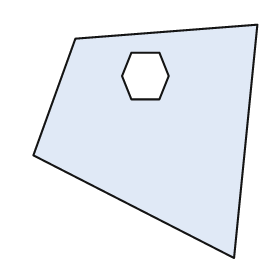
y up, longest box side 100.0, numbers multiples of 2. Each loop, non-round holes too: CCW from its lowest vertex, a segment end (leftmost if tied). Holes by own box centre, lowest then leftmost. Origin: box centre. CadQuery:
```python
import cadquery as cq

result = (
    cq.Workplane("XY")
    .moveTo(38.0, -50.0)
    .lineTo(48.0, 50.0)
    .lineTo(-30.0, 44.0)
    .lineTo(-48.0, -6.0)
    .close()
    .moveTo(-6.0, 18.0)
    .lineTo(6.0, 18.0)
    .lineTo(10.0, 28.0)
    .lineTo(6.0, 38.0)
    .lineTo(-6.0, 38.0)
    .lineTo(-10.0, 28.0)
    .close()
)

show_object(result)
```